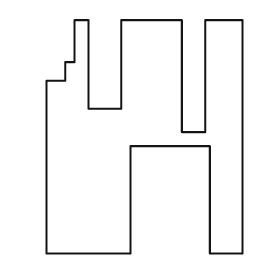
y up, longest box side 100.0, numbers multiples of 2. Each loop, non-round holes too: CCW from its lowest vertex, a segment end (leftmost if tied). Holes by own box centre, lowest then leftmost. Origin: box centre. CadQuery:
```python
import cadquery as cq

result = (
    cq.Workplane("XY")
    .moveTo(-42.0, -50.0)
    .lineTo(-6.0, -50.0)
    .lineTo(-6.0, -4.0)
    .lineTo(28.0, -4.0)
    .lineTo(28.0, -50.0)
    .lineTo(42.0, -50.0)
    .lineTo(42.0, 50.0)
    .lineTo(26.0, 50.0)
    .lineTo(26.0, 2.0)
    .lineTo(16.0, 2.0)
    .lineTo(16.0, 50.0)
    .lineTo(-10.0, 50.0)
    .lineTo(-10.0, 12.0)
    .lineTo(-24.0, 12.0)
    .lineTo(-24.0, 50.0)
    .lineTo(-30.0, 50.0)
    .lineTo(-30.0, 32.0)
    .lineTo(-34.0, 32.0)
    .lineTo(-34.0, 24.0)
    .lineTo(-42.0, 24.0)
    .close()
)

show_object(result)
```